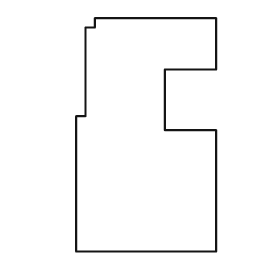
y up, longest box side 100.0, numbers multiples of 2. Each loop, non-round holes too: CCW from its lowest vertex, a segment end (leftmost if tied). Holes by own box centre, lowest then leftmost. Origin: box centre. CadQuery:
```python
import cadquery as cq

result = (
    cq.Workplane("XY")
    .moveTo(-30.0, -50.0)
    .lineTo(30.0, -50.0)
    .lineTo(30.0, 2.0)
    .lineTo(8.0, 2.0)
    .lineTo(8.0, 28.0)
    .lineTo(30.0, 28.0)
    .lineTo(30.0, 50.0)
    .lineTo(-22.0, 50.0)
    .lineTo(-22.0, 46.0)
    .lineTo(-26.0, 46.0)
    .lineTo(-26.0, 8.0)
    .lineTo(-30.0, 8.0)
    .close()
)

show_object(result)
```